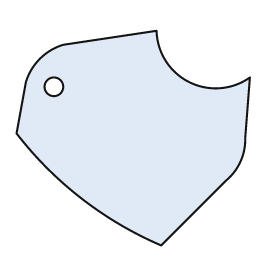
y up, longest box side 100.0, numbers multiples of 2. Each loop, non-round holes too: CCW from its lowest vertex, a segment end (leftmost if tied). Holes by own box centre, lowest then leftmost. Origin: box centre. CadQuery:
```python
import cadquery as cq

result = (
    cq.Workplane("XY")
    .moveTo(12.0, -46.0)
    .lineTo(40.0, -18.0)
    .threePointArc((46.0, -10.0), (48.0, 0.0))
    .lineTo(50.0, 26.0)
    .threePointArc((24.0, 24.0), (10.0, 46.0))
    .lineTo(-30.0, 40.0)
    .threePointArc((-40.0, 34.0), (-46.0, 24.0))
    .lineTo(-50.0, 2.0)
    .threePointArc((-22.0, -26.0), (12.0, -46.0))
    .close()
    .moveTo(-34.0, 22.0)
    .circle(4.0)
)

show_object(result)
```